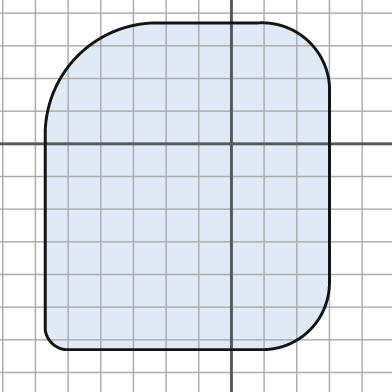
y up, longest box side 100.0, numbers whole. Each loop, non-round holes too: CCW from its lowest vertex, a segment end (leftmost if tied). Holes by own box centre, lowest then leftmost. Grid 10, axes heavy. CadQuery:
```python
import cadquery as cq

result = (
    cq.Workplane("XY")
    .moveTo(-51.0, -63.0)
    .lineTo(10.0, -63.0)
    .threePointArc((24.0, -57.0), (30.0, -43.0))
    .lineTo(30.0, 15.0)
    .threePointArc((24.0, 31.0), (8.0, 37.0))
    .lineTo(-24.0, 37.0)
    .threePointArc((-47.0, 27.0), (-57.0, 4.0))
    .lineTo(-57.0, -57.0)
    .threePointArc((-55.0, -61.0), (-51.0, -63.0))
    .close()
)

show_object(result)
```